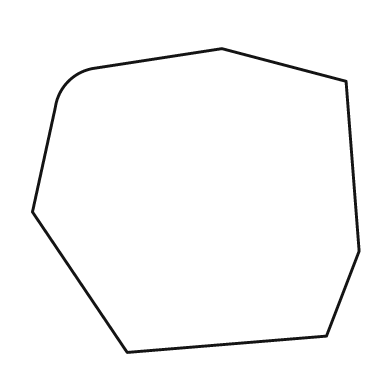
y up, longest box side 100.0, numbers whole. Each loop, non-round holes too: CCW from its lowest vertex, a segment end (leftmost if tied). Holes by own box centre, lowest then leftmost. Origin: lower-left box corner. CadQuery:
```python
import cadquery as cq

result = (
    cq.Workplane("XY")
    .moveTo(29.0, 0.0)
    .lineTo(90.0, 5.0)
    .lineTo(100.0, 31.0)
    .lineTo(96.0, 83.0)
    .lineTo(58.0, 93.0)
    .lineTo(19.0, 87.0)
    .threePointArc((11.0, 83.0), (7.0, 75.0))
    .lineTo(0.0, 43.0)
    .close()
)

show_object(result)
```